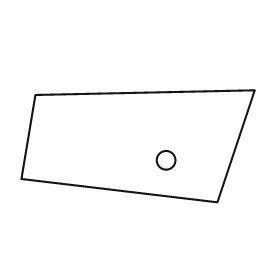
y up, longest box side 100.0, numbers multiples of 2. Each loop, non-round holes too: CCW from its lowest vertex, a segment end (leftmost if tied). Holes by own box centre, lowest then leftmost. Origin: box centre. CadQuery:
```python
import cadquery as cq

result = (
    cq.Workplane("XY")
    .moveTo(34.0, -24.0)
    .lineTo(50.0, 24.0)
    .lineTo(-44.0, 22.0)
    .lineTo(-50.0, -14.0)
    .close()
    .moveTo(12.0, -6.0)
    .circle(4.0)
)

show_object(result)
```